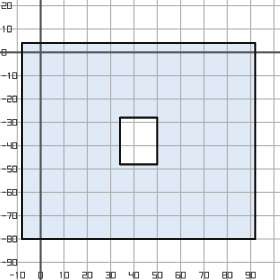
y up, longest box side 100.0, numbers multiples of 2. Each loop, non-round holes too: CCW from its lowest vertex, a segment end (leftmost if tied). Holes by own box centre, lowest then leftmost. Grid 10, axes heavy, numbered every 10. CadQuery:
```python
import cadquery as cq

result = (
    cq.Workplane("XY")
    .moveTo(-8.0, -80.0)
    .lineTo(92.0, -80.0)
    .lineTo(92.0, 4.0)
    .lineTo(-8.0, 4.0)
    .close()
    .moveTo(34.0, -48.0)
    .lineTo(50.0, -48.0)
    .lineTo(50.0, -28.0)
    .lineTo(34.0, -28.0)
    .close()
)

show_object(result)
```